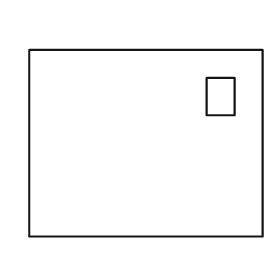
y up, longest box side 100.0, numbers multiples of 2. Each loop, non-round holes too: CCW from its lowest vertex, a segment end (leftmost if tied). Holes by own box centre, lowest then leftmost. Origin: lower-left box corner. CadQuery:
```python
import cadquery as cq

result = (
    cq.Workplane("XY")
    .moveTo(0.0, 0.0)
    .lineTo(100.0, 0.0)
    .lineTo(100.0, 80.0)
    .lineTo(0.0, 80.0)
    .close()
    .moveTo(76.0, 52.0)
    .lineTo(88.0, 52.0)
    .lineTo(88.0, 68.0)
    .lineTo(76.0, 68.0)
    .close()
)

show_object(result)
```